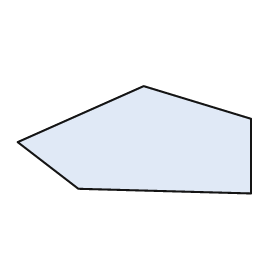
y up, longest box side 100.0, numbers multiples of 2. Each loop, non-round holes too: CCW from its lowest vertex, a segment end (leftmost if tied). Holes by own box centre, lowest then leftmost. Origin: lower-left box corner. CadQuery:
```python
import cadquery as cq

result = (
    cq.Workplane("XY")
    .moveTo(100.0, 0.0)
    .lineTo(100.0, 32.0)
    .lineTo(54.0, 46.0)
    .lineTo(0.0, 22.0)
    .lineTo(26.0, 2.0)
    .close()
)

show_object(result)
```